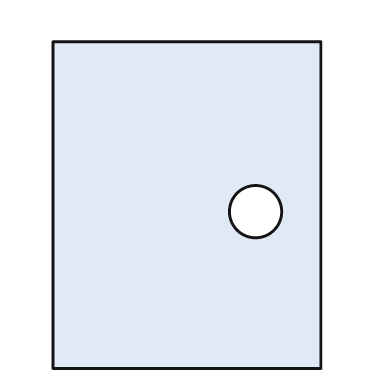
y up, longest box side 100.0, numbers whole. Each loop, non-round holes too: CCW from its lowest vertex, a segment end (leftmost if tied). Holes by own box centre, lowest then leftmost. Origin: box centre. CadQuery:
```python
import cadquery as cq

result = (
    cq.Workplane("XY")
    .moveTo(-41.0, -50.0)
    .lineTo(41.0, -50.0)
    .lineTo(41.0, 50.0)
    .lineTo(-41.0, 50.0)
    .close()
    .moveTo(21.0, -2.0)
    .circle(8.0)
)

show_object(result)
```